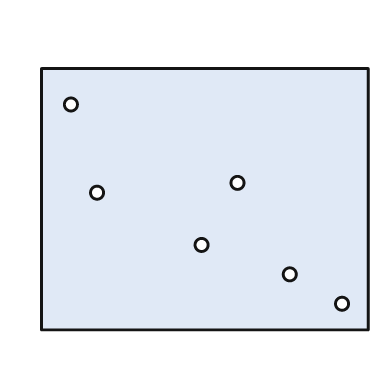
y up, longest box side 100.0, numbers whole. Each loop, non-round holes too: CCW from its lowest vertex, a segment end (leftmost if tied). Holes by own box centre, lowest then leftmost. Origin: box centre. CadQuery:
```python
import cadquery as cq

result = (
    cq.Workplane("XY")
    .moveTo(-50.0, -40.0)
    .lineTo(50.0, -40.0)
    .lineTo(50.0, 40.0)
    .lineTo(-50.0, 40.0)
    .close()
    .moveTo(42.0, -32.0)
    .circle(2.0)
    .moveTo(26.0, -23.0)
    .circle(2.0)
    .moveTo(-1.0, -14.0)
    .circle(2.0)
    .moveTo(-33.0, 2.0)
    .circle(2.0)
    .moveTo(10.0, 5.0)
    .circle(2.0)
    .moveTo(-41.0, 29.0)
    .circle(2.0)
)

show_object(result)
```